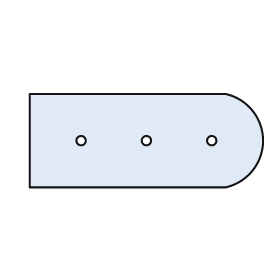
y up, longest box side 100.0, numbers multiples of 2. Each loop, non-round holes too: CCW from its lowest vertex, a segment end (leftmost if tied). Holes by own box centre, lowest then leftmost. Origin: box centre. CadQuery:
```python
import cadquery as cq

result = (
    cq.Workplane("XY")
    .moveTo(-50.0, -20.0)
    .lineTo(34.0, -20.0)
    .threePointArc((50.0, 0.0), (34.0, 20.0))
    .lineTo(-50.0, 20.0)
    .close()
    .moveTo(-28.0, 0.0)
    .circle(2.0)
    .moveTo(0.0, 0.0)
    .circle(2.0)
    .moveTo(28.0, 0.0)
    .circle(2.0)
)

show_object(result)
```